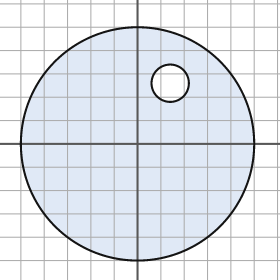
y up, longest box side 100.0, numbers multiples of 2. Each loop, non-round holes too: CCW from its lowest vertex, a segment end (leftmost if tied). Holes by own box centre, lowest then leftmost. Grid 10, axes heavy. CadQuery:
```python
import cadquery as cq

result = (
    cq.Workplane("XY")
    .moveTo(0.0, 0.0)
    .circle(50.0)
    .moveTo(14.0, 26.0)
    .circle(8.0)
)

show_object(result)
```